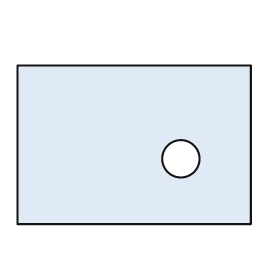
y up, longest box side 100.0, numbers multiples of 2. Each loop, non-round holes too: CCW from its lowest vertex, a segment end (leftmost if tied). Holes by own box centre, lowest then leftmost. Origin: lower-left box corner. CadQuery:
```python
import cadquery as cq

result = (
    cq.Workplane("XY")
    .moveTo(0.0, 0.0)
    .lineTo(100.0, 0.0)
    .lineTo(100.0, 68.0)
    .lineTo(0.0, 68.0)
    .close()
    .moveTo(70.0, 28.0)
    .circle(8.0)
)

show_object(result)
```